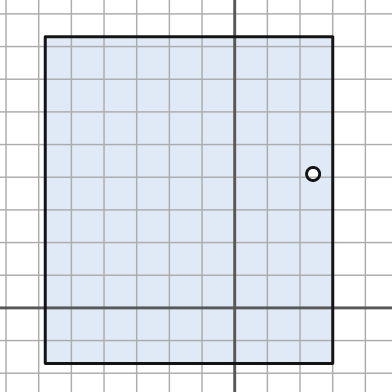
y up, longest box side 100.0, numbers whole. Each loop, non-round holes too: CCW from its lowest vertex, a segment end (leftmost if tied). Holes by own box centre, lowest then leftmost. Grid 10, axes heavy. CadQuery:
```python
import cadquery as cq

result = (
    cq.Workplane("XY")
    .moveTo(-58.0, -17.0)
    .lineTo(30.0, -17.0)
    .lineTo(30.0, 83.0)
    .lineTo(-58.0, 83.0)
    .close()
    .moveTo(24.0, 41.0)
    .circle(2.0)
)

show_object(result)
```